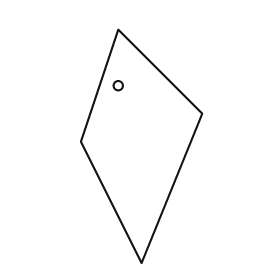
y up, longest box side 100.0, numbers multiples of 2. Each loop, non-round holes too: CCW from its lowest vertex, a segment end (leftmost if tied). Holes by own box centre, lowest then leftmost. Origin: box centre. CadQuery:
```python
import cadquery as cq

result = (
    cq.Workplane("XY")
    .moveTo(0.0, -50.0)
    .lineTo(26.0, 14.0)
    .lineTo(-10.0, 50.0)
    .lineTo(-26.0, 2.0)
    .close()
    .moveTo(-10.0, 26.0)
    .circle(2.0)
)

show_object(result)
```